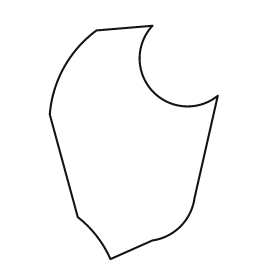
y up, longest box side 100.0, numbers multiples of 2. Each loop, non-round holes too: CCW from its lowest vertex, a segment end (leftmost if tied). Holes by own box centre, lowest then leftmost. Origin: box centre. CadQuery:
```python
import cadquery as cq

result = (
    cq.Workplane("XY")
    .moveTo(-10.0, -50.0)
    .lineTo(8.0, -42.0)
    .threePointArc((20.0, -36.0), (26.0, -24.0))
    .lineTo(36.0, 20.0)
    .threePointArc((8.0, 22.0), (8.0, 50.0))
    .lineTo(-16.0, 48.0)
    .threePointArc((-30.0, 32.0), (-36.0, 12.0))
    .lineTo(-24.0, -32.0)
    .threePointArc((-16.0, -40.0), (-10.0, -50.0))
    .close()
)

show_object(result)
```